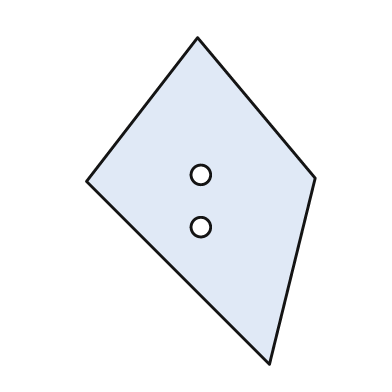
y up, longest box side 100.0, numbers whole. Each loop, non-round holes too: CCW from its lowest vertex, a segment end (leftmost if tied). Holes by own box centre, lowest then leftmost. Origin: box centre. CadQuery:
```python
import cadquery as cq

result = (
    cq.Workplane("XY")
    .moveTo(21.0, -50.0)
    .lineTo(35.0, 7.0)
    .lineTo(-1.0, 50.0)
    .lineTo(-35.0, 6.0)
    .close()
    .moveTo(0.0, -8.0)
    .circle(3.0)
    .moveTo(0.0, 8.0)
    .circle(3.0)
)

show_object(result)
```